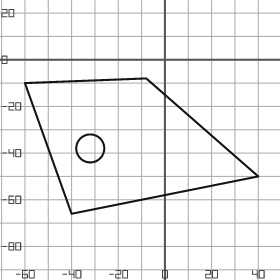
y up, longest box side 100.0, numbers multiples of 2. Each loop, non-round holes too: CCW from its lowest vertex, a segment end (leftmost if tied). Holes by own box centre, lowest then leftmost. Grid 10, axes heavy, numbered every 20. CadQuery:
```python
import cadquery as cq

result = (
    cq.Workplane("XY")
    .moveTo(-40.0, -66.0)
    .lineTo(40.0, -50.0)
    .lineTo(-8.0, -8.0)
    .lineTo(-60.0, -10.0)
    .close()
    .moveTo(-32.0, -38.0)
    .circle(6.0)
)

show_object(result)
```